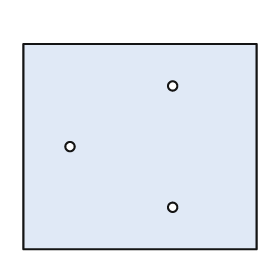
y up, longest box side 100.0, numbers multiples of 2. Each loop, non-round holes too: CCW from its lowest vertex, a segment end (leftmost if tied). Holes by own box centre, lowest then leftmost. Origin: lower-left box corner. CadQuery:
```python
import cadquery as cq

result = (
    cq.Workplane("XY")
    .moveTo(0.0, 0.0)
    .lineTo(100.0, 0.0)
    .lineTo(100.0, 88.0)
    .lineTo(0.0, 88.0)
    .close()
    .moveTo(64.0, 18.0)
    .circle(2.0)
    .moveTo(20.0, 44.0)
    .circle(2.0)
    .moveTo(64.0, 70.0)
    .circle(2.0)
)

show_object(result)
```